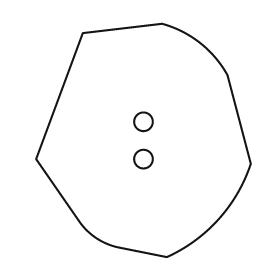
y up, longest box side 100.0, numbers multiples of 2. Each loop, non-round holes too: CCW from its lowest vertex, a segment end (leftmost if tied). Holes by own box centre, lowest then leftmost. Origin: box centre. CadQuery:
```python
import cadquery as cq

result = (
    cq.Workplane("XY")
    .moveTo(10.0, -50.0)
    .threePointArc((32.0, -34.0), (46.0, -10.0))
    .lineTo(36.0, 28.0)
    .threePointArc((24.0, 42.0), (8.0, 50.0))
    .lineTo(-26.0, 46.0)
    .lineTo(-46.0, -8.0)
    .lineTo(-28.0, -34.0)
    .threePointArc((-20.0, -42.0), (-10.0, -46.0))
    .close()
    .moveTo(0.0, -8.0)
    .circle(4.0)
    .moveTo(0.0, 8.0)
    .circle(4.0)
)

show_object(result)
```